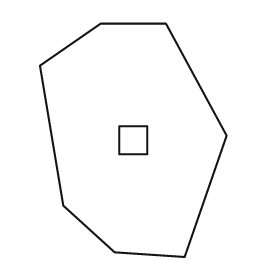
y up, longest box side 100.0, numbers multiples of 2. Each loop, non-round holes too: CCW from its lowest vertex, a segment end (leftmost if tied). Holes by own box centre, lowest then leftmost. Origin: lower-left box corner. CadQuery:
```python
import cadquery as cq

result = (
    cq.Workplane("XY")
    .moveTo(62.0, 0.0)
    .lineTo(80.0, 52.0)
    .lineTo(54.0, 100.0)
    .lineTo(26.0, 100.0)
    .lineTo(0.0, 82.0)
    .lineTo(10.0, 22.0)
    .lineTo(32.0, 2.0)
    .close()
    .moveTo(34.0, 44.0)
    .lineTo(46.0, 44.0)
    .lineTo(46.0, 56.0)
    .lineTo(34.0, 56.0)
    .close()
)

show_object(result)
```